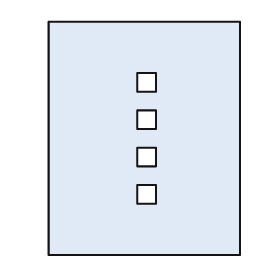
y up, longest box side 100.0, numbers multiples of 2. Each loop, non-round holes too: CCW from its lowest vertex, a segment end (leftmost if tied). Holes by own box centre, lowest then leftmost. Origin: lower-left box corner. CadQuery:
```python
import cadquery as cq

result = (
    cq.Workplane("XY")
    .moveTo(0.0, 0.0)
    .lineTo(82.0, 0.0)
    .lineTo(82.0, 100.0)
    .lineTo(0.0, 100.0)
    .close()
    .moveTo(38.0, 22.0)
    .lineTo(46.0, 22.0)
    .lineTo(46.0, 30.0)
    .lineTo(38.0, 30.0)
    .close()
    .moveTo(38.0, 38.0)
    .lineTo(46.0, 38.0)
    .lineTo(46.0, 46.0)
    .lineTo(38.0, 46.0)
    .close()
    .moveTo(38.0, 54.0)
    .lineTo(46.0, 54.0)
    .lineTo(46.0, 62.0)
    .lineTo(38.0, 62.0)
    .close()
    .moveTo(38.0, 70.0)
    .lineTo(46.0, 70.0)
    .lineTo(46.0, 78.0)
    .lineTo(38.0, 78.0)
    .close()
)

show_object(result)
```